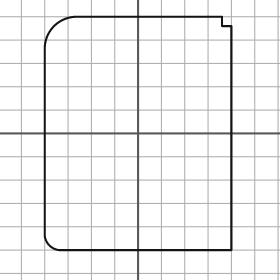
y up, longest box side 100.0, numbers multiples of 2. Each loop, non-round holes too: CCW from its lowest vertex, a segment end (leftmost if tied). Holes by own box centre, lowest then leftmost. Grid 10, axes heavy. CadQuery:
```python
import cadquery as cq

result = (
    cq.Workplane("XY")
    .moveTo(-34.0, -50.0)
    .lineTo(40.0, -50.0)
    .lineTo(40.0, 46.0)
    .lineTo(36.0, 46.0)
    .lineTo(36.0, 50.0)
    .lineTo(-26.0, 50.0)
    .threePointArc((-36.0, 46.0), (-40.0, 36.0))
    .lineTo(-40.0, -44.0)
    .threePointArc((-38.0, -48.0), (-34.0, -50.0))
    .close()
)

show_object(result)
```